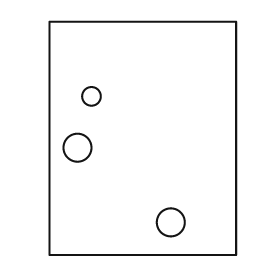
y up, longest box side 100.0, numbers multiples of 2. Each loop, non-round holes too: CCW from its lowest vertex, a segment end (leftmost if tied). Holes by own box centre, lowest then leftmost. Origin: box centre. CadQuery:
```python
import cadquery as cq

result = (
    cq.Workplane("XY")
    .moveTo(-40.0, -50.0)
    .lineTo(40.0, -50.0)
    .lineTo(40.0, 50.0)
    .lineTo(-40.0, 50.0)
    .close()
    .moveTo(12.0, -36.0)
    .circle(6.0)
    .moveTo(-28.0, -4.0)
    .circle(6.0)
    .moveTo(-22.0, 18.0)
    .circle(4.0)
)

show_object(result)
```